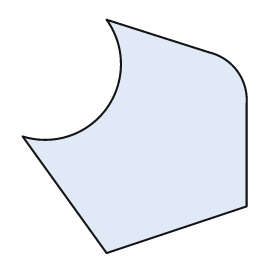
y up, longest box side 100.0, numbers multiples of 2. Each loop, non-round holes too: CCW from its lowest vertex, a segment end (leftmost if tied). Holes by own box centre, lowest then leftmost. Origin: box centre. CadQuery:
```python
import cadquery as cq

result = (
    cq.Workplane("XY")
    .moveTo(-12.0, -50.0)
    .lineTo(48.0, -30.0)
    .lineTo(48.0, 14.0)
    .threePointArc((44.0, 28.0), (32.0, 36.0))
    .lineTo(-12.0, 50.0)
    .threePointArc((-12.0, 12.0), (-48.0, 0.0))
    .close()
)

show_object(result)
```